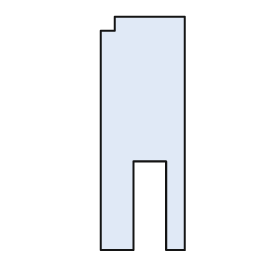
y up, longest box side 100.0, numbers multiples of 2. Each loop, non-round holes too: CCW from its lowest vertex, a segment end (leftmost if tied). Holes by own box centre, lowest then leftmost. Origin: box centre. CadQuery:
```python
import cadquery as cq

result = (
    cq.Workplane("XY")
    .moveTo(-18.0, -50.0)
    .lineTo(-4.0, -50.0)
    .lineTo(-4.0, -12.0)
    .lineTo(10.0, -12.0)
    .lineTo(10.0, -50.0)
    .lineTo(18.0, -50.0)
    .lineTo(18.0, 50.0)
    .lineTo(-12.0, 50.0)
    .lineTo(-12.0, 44.0)
    .lineTo(-18.0, 44.0)
    .close()
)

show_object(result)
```